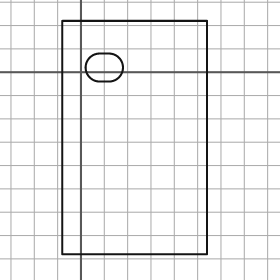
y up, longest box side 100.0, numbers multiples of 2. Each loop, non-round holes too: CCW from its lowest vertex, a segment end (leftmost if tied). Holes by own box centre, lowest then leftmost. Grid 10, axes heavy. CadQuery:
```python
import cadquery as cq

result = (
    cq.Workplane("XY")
    .moveTo(-8.0, -78.0)
    .lineTo(54.0, -78.0)
    .lineTo(54.0, 22.0)
    .lineTo(-8.0, 22.0)
    .close()
    .moveTo(8.0, -4.0)
    .lineTo(12.0, -4.0)
    .threePointArc((18.0, 2.0), (12.0, 8.0))
    .lineTo(8.0, 8.0)
    .threePointArc((2.0, 2.0), (8.0, -4.0))
    .close()
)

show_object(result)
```